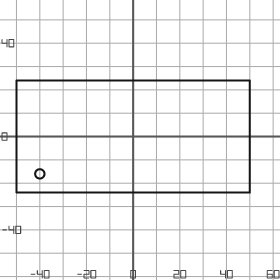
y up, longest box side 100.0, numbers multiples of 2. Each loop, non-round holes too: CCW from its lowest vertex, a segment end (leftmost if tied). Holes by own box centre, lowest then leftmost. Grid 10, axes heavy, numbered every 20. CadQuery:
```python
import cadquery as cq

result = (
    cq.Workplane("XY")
    .moveTo(-50.0, -24.0)
    .lineTo(50.0, -24.0)
    .lineTo(50.0, 24.0)
    .lineTo(-50.0, 24.0)
    .close()
    .moveTo(-40.0, -16.0)
    .circle(2.0)
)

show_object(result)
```